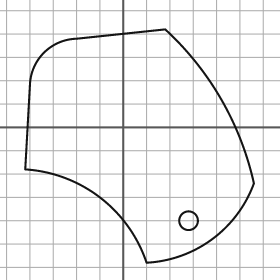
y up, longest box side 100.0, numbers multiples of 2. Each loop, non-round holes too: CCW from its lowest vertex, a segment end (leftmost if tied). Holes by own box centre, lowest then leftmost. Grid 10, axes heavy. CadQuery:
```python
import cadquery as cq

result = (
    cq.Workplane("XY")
    .moveTo(10.0, -58.0)
    .threePointArc((38.0, -48.0), (56.0, -24.0))
    .threePointArc((42.0, 12.0), (18.0, 42.0))
    .lineTo(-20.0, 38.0)
    .threePointArc((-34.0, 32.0), (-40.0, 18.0))
    .lineTo(-42.0, -18.0)
    .threePointArc((-10.0, -30.0), (10.0, -58.0))
    .close()
    .moveTo(28.0, -40.0)
    .circle(4.0)
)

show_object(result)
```